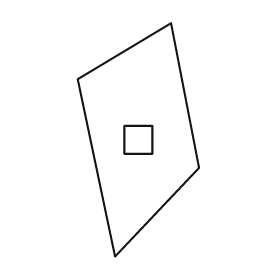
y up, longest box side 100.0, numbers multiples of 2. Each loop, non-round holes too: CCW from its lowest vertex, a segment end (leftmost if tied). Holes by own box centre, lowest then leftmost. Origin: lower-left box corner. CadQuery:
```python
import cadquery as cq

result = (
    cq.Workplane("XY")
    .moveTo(16.0, 0.0)
    .lineTo(52.0, 38.0)
    .lineTo(40.0, 100.0)
    .lineTo(0.0, 76.0)
    .close()
    .moveTo(20.0, 44.0)
    .lineTo(32.0, 44.0)
    .lineTo(32.0, 56.0)
    .lineTo(20.0, 56.0)
    .close()
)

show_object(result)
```